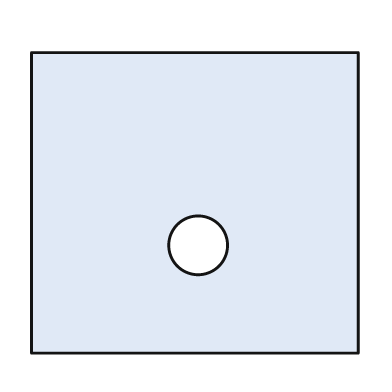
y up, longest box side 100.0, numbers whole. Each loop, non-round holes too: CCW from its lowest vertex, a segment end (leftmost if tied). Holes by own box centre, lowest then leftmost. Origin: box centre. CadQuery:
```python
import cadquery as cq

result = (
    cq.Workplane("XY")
    .moveTo(-50.0, -46.0)
    .lineTo(50.0, -46.0)
    .lineTo(50.0, 46.0)
    .lineTo(-50.0, 46.0)
    .close()
    .moveTo(1.0, -13.0)
    .circle(9.0)
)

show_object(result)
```